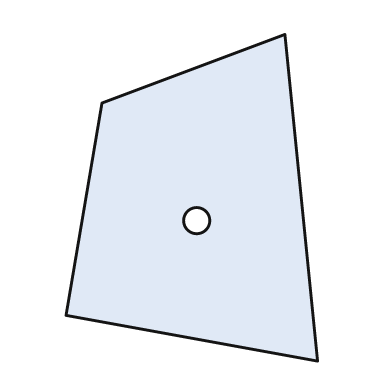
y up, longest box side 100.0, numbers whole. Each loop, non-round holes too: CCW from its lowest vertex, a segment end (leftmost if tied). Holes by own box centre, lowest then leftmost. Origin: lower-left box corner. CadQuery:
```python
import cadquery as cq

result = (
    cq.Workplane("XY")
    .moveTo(77.0, 0.0)
    .lineTo(67.0, 100.0)
    .lineTo(11.0, 79.0)
    .lineTo(0.0, 14.0)
    .close()
    .moveTo(40.0, 43.0)
    .circle(4.0)
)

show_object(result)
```